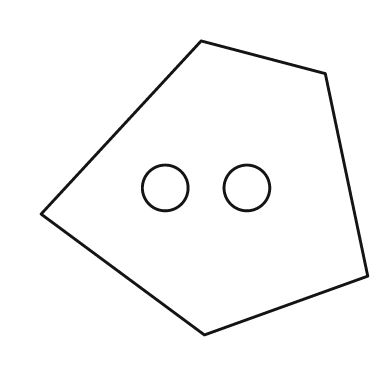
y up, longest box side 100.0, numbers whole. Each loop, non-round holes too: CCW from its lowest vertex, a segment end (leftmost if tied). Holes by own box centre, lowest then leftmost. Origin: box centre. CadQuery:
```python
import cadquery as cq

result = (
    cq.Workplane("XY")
    .moveTo(0.0, -45.0)
    .lineTo(50.0, -27.0)
    .lineTo(37.0, 35.0)
    .lineTo(-1.0, 45.0)
    .lineTo(-50.0, -8.0)
    .close()
    .moveTo(-12.0, 0.0)
    .circle(7.0)
    .moveTo(13.0, 0.0)
    .circle(7.0)
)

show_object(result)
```